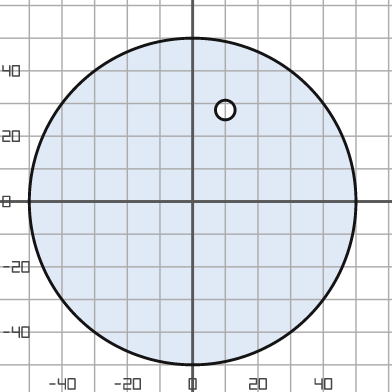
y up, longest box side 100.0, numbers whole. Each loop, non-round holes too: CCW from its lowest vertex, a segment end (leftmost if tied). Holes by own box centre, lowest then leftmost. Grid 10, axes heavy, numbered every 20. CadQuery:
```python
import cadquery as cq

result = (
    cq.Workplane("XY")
    .moveTo(0.0, 0.0)
    .circle(50.0)
    .moveTo(10.0, 28.0)
    .circle(3.0)
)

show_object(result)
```